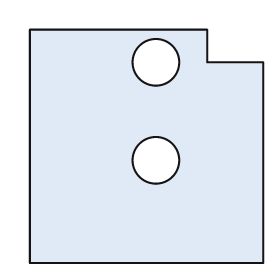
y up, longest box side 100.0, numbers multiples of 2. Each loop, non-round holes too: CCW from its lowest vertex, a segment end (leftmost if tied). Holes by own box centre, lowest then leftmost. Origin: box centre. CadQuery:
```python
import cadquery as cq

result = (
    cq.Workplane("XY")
    .moveTo(-50.0, -50.0)
    .lineTo(50.0, -50.0)
    .lineTo(50.0, 36.0)
    .lineTo(26.0, 36.0)
    .lineTo(26.0, 50.0)
    .lineTo(-50.0, 50.0)
    .close()
    .moveTo(4.0, -6.0)
    .circle(10.0)
    .moveTo(4.0, 36.0)
    .circle(10.0)
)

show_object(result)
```